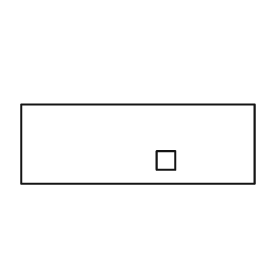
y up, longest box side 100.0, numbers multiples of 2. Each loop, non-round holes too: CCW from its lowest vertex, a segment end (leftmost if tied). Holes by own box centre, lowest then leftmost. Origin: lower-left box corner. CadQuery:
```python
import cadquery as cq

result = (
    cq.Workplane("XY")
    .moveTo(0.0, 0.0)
    .lineTo(100.0, 0.0)
    .lineTo(100.0, 34.0)
    .lineTo(0.0, 34.0)
    .close()
    .moveTo(58.0, 6.0)
    .lineTo(66.0, 6.0)
    .lineTo(66.0, 14.0)
    .lineTo(58.0, 14.0)
    .close()
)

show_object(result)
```